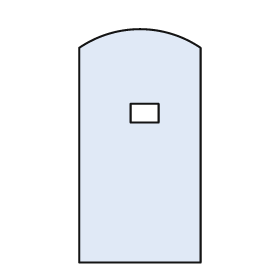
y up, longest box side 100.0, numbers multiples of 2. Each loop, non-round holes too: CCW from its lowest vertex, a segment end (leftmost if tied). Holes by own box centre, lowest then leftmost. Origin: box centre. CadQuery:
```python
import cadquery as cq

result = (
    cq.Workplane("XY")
    .moveTo(-26.0, -50.0)
    .lineTo(26.0, -50.0)
    .lineTo(26.0, 42.0)
    .threePointArc((0.0, 50.0), (-26.0, 42.0))
    .close()
    .moveTo(-4.0, 10.0)
    .lineTo(8.0, 10.0)
    .lineTo(8.0, 18.0)
    .lineTo(-4.0, 18.0)
    .close()
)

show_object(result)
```